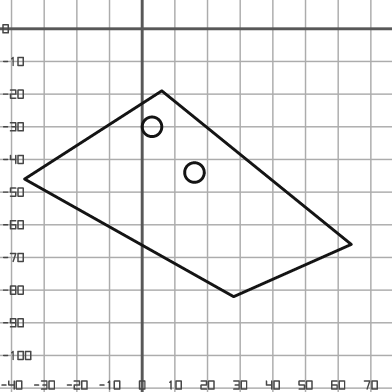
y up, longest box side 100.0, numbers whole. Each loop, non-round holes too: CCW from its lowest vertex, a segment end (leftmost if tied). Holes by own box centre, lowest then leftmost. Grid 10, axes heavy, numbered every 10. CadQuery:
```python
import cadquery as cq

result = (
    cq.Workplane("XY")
    .moveTo(28.0, -82.0)
    .lineTo(64.0, -66.0)
    .lineTo(6.0, -19.0)
    .lineTo(-36.0, -46.0)
    .close()
    .moveTo(16.0, -44.0)
    .circle(3.0)
    .moveTo(3.0, -30.0)
    .circle(3.0)
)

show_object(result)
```